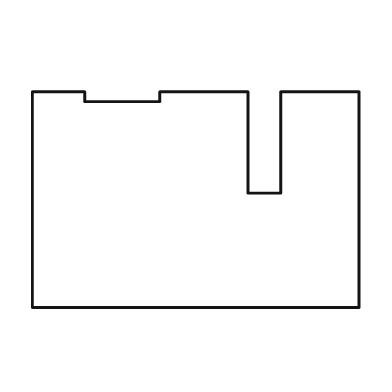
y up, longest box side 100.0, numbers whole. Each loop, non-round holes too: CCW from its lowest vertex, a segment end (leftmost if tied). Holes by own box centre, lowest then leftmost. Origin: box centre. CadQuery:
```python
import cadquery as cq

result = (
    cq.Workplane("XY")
    .moveTo(-50.0, -33.0)
    .lineTo(50.0, -33.0)
    .lineTo(50.0, 33.0)
    .lineTo(26.0, 33.0)
    .lineTo(26.0, 2.0)
    .lineTo(16.0, 2.0)
    .lineTo(16.0, 33.0)
    .lineTo(-11.0, 33.0)
    .lineTo(-11.0, 30.0)
    .lineTo(-34.0, 30.0)
    .lineTo(-34.0, 33.0)
    .lineTo(-50.0, 33.0)
    .close()
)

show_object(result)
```